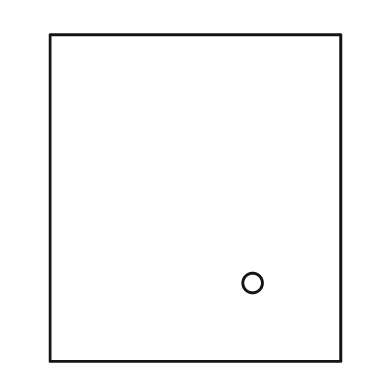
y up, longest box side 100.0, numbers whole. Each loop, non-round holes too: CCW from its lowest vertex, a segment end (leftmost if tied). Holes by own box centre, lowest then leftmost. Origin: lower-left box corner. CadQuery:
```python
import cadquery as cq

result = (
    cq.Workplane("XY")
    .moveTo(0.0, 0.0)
    .lineTo(89.0, 0.0)
    .lineTo(89.0, 100.0)
    .lineTo(0.0, 100.0)
    .close()
    .moveTo(62.0, 24.0)
    .circle(3.0)
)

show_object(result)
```